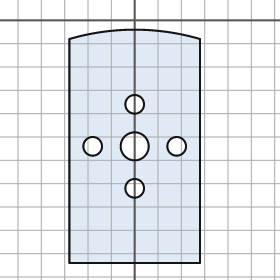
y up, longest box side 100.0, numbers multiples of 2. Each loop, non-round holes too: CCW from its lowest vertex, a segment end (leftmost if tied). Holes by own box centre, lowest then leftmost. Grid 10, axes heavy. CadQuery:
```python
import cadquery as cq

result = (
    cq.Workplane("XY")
    .moveTo(-28.0, -104.0)
    .lineTo(28.0, -104.0)
    .lineTo(28.0, -8.0)
    .threePointArc((0.0, -4.0), (-28.0, -8.0))
    .close()
    .moveTo(0.0, -72.0)
    .circle(4.0)
    .moveTo(-18.0, -54.0)
    .circle(4.0)
    .moveTo(0.0, -54.0)
    .circle(6.0)
    .moveTo(18.0, -54.0)
    .circle(4.0)
    .moveTo(0.0, -36.0)
    .circle(4.0)
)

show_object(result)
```